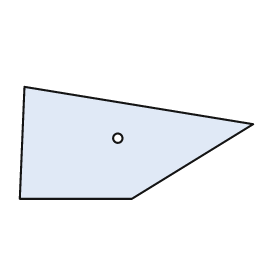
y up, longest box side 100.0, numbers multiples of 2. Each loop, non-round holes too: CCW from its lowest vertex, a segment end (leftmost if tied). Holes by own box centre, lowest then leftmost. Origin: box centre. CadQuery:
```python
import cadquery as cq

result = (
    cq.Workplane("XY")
    .moveTo(-50.0, -24.0)
    .lineTo(-2.0, -24.0)
    .lineTo(50.0, 8.0)
    .lineTo(-48.0, 24.0)
    .close()
    .moveTo(-8.0, 2.0)
    .circle(2.0)
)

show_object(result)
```